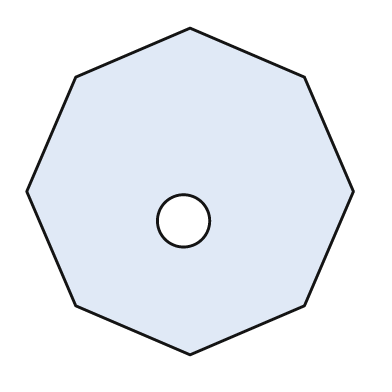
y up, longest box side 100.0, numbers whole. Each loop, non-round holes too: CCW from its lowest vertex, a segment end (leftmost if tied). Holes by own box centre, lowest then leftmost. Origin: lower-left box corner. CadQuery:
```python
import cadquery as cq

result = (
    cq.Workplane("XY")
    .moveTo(50.0, 0.0)
    .lineTo(85.0, 15.0)
    .lineTo(100.0, 50.0)
    .lineTo(85.0, 85.0)
    .lineTo(50.0, 100.0)
    .lineTo(15.0, 85.0)
    .lineTo(0.0, 50.0)
    .lineTo(15.0, 15.0)
    .close()
    .moveTo(48.0, 41.0)
    .circle(8.0)
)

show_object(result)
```